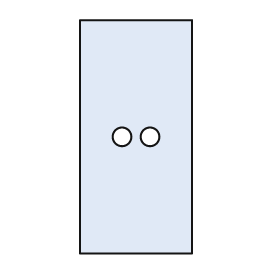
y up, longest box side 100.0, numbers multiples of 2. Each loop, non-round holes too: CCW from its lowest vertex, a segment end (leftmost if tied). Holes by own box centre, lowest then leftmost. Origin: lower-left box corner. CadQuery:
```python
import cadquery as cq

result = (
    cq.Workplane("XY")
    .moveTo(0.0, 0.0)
    .lineTo(48.0, 0.0)
    .lineTo(48.0, 100.0)
    .lineTo(0.0, 100.0)
    .close()
    .moveTo(18.0, 50.0)
    .circle(4.0)
    .moveTo(30.0, 50.0)
    .circle(4.0)
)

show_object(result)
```